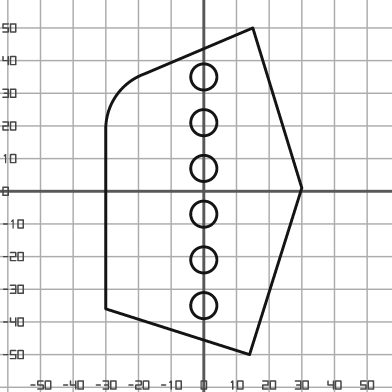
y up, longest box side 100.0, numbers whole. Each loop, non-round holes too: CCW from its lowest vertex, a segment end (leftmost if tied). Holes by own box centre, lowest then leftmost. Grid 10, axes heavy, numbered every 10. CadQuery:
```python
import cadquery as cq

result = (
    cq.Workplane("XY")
    .moveTo(14.0, -50.0)
    .lineTo(30.0, 1.0)
    .lineTo(15.0, 50.0)
    .lineTo(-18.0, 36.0)
    .threePointArc((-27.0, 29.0), (-30.0, 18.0))
    .lineTo(-30.0, -36.0)
    .close()
    .moveTo(0.0, -35.0)
    .circle(4.0)
    .moveTo(0.0, -21.0)
    .circle(4.0)
    .moveTo(0.0, -7.0)
    .circle(4.0)
    .moveTo(0.0, 7.0)
    .circle(4.0)
    .moveTo(0.0, 21.0)
    .circle(4.0)
    .moveTo(0.0, 35.0)
    .circle(4.0)
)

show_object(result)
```